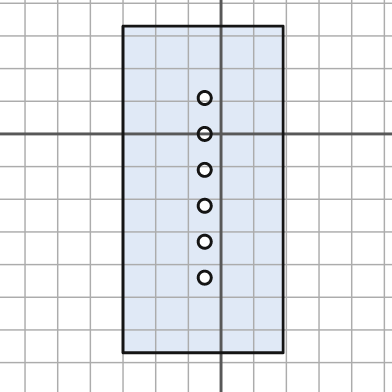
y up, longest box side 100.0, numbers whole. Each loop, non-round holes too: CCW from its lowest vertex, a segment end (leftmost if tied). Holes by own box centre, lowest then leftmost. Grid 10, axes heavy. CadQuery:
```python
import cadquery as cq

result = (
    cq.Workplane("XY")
    .moveTo(-30.0, -67.0)
    .lineTo(19.0, -67.0)
    .lineTo(19.0, 33.0)
    .lineTo(-30.0, 33.0)
    .close()
    .moveTo(-5.0, -44.0)
    .circle(2.0)
    .moveTo(-5.0, -33.0)
    .circle(2.0)
    .moveTo(-5.0, -22.0)
    .circle(2.0)
    .moveTo(-5.0, -11.0)
    .circle(2.0)
    .moveTo(-5.0, 0.0)
    .circle(2.0)
    .moveTo(-5.0, 11.0)
    .circle(2.0)
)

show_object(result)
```